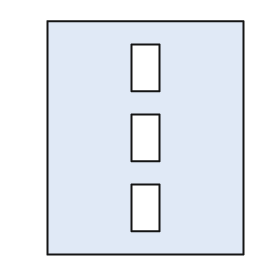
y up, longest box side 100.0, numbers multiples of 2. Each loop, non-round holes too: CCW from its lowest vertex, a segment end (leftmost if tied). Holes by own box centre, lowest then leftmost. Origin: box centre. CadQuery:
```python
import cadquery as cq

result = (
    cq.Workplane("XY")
    .moveTo(-42.0, -50.0)
    .lineTo(42.0, -50.0)
    .lineTo(42.0, 50.0)
    .lineTo(-42.0, 50.0)
    .close()
    .moveTo(-6.0, -40.0)
    .lineTo(6.0, -40.0)
    .lineTo(6.0, -20.0)
    .lineTo(-6.0, -20.0)
    .close()
    .moveTo(-6.0, -10.0)
    .lineTo(6.0, -10.0)
    .lineTo(6.0, 10.0)
    .lineTo(-6.0, 10.0)
    .close()
    .moveTo(-6.0, 20.0)
    .lineTo(6.0, 20.0)
    .lineTo(6.0, 40.0)
    .lineTo(-6.0, 40.0)
    .close()
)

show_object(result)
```